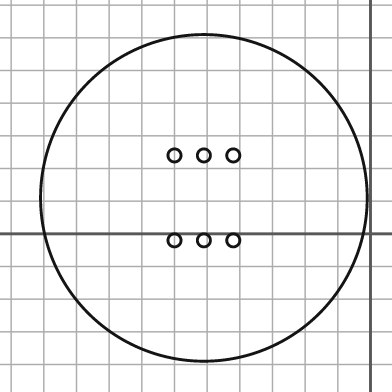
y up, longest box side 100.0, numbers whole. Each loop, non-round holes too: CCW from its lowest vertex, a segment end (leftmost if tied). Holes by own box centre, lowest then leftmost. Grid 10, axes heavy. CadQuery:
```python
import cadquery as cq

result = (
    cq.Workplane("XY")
    .moveTo(-51.0, 11.0)
    .circle(50.0)
    .moveTo(-60.0, -2.0)
    .circle(2.0)
    .moveTo(-51.0, -2.0)
    .circle(2.0)
    .moveTo(-42.0, -2.0)
    .circle(2.0)
    .moveTo(-60.0, 24.0)
    .circle(2.0)
    .moveTo(-51.0, 24.0)
    .circle(2.0)
    .moveTo(-42.0, 24.0)
    .circle(2.0)
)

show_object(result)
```